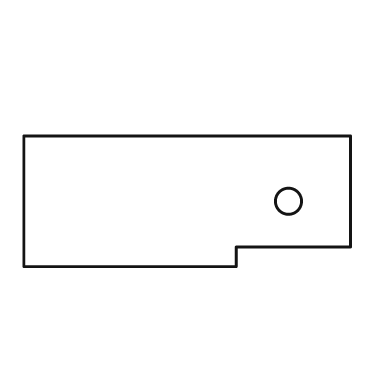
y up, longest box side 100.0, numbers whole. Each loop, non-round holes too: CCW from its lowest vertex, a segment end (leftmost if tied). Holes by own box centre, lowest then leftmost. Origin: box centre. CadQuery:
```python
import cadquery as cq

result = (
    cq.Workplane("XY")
    .moveTo(-50.0, -20.0)
    .lineTo(15.0, -20.0)
    .lineTo(15.0, -14.0)
    .lineTo(50.0, -14.0)
    .lineTo(50.0, 20.0)
    .lineTo(-50.0, 20.0)
    .close()
    .moveTo(31.0, 0.0)
    .circle(4.0)
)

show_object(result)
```